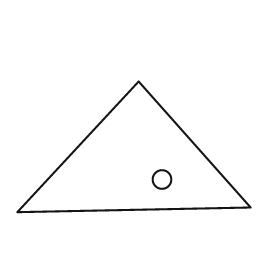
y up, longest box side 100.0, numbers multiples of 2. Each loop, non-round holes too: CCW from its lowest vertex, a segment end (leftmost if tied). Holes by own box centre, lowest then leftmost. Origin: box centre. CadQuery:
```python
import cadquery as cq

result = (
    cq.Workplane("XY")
    .moveTo(-50.0, -28.0)
    .lineTo(50.0, -26.0)
    .lineTo(2.0, 28.0)
    .close()
    .moveTo(12.0, -14.0)
    .circle(4.0)
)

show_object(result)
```